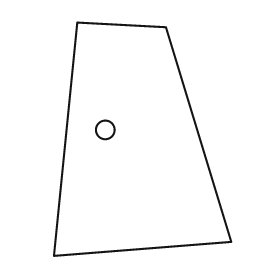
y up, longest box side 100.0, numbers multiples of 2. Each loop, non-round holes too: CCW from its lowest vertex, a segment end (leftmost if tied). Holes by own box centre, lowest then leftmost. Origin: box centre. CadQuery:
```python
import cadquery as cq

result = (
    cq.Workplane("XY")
    .moveTo(-38.0, -50.0)
    .lineTo(38.0, -44.0)
    .lineTo(10.0, 48.0)
    .lineTo(-28.0, 50.0)
    .close()
    .moveTo(-16.0, 4.0)
    .circle(4.0)
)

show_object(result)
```